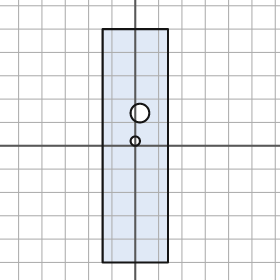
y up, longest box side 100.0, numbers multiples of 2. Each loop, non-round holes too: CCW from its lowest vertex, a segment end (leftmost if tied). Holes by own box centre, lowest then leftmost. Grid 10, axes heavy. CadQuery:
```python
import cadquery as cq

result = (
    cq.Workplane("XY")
    .moveTo(-14.0, -50.0)
    .lineTo(14.0, -50.0)
    .lineTo(14.0, 50.0)
    .lineTo(-14.0, 50.0)
    .close()
    .moveTo(0.0, 2.0)
    .circle(2.0)
    .moveTo(2.0, 14.0)
    .circle(4.0)
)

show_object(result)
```